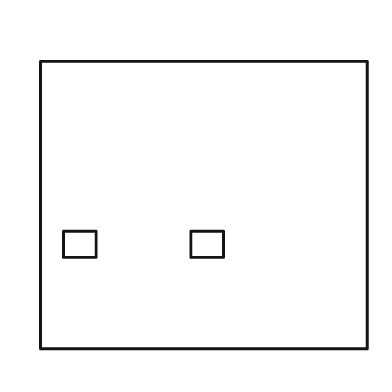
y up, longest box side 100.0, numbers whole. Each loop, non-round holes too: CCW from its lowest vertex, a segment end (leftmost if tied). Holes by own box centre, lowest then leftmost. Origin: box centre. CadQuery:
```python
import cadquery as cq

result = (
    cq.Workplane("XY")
    .moveTo(-50.0, -44.0)
    .lineTo(50.0, -44.0)
    .lineTo(50.0, 44.0)
    .lineTo(-50.0, 44.0)
    .close()
    .moveTo(-43.0, -16.0)
    .lineTo(-33.0, -16.0)
    .lineTo(-33.0, -8.0)
    .lineTo(-43.0, -8.0)
    .close()
    .moveTo(-4.0, -16.0)
    .lineTo(6.0, -16.0)
    .lineTo(6.0, -8.0)
    .lineTo(-4.0, -8.0)
    .close()
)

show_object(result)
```